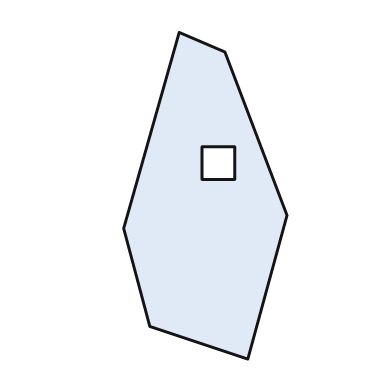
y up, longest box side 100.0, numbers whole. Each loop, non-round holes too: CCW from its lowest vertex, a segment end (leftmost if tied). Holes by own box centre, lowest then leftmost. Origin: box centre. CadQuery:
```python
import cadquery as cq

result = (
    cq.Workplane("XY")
    .moveTo(13.0, -50.0)
    .lineTo(25.0, -6.0)
    .lineTo(6.0, 44.0)
    .lineTo(-8.0, 50.0)
    .lineTo(-25.0, -10.0)
    .lineTo(-17.0, -40.0)
    .close()
    .moveTo(-1.0, 5.0)
    .lineTo(9.0, 5.0)
    .lineTo(9.0, 15.0)
    .lineTo(-1.0, 15.0)
    .close()
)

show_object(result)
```